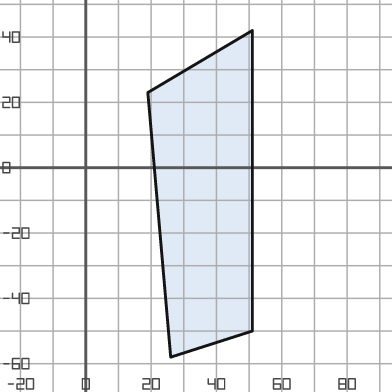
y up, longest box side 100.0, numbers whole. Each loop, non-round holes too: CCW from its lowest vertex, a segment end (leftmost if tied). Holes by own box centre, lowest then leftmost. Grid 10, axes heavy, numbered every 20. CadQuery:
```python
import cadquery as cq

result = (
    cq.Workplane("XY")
    .moveTo(26.0, -58.0)
    .lineTo(51.0, -50.0)
    .lineTo(51.0, 42.0)
    .lineTo(19.0, 23.0)
    .close()
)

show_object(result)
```